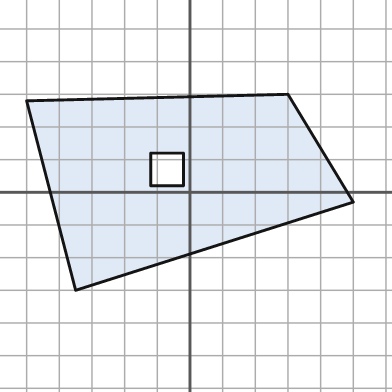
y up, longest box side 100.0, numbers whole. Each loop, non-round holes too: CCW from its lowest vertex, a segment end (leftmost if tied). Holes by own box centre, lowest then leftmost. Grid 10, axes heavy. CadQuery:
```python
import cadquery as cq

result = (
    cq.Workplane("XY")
    .moveTo(-35.0, -30.0)
    .lineTo(50.0, -3.0)
    .lineTo(30.0, 30.0)
    .lineTo(-50.0, 28.0)
    .close()
    .moveTo(-12.0, 2.0)
    .lineTo(-2.0, 2.0)
    .lineTo(-2.0, 12.0)
    .lineTo(-12.0, 12.0)
    .close()
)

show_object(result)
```